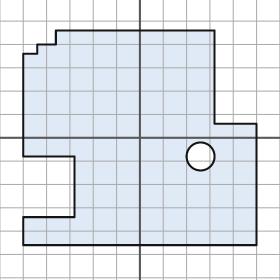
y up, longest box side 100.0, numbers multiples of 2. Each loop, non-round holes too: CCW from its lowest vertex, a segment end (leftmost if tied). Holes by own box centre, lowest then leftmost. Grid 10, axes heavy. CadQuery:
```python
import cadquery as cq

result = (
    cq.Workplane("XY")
    .moveTo(-50.0, -46.0)
    .lineTo(50.0, -46.0)
    .lineTo(50.0, 6.0)
    .lineTo(32.0, 6.0)
    .lineTo(32.0, 46.0)
    .lineTo(-36.0, 46.0)
    .lineTo(-36.0, 40.0)
    .lineTo(-44.0, 40.0)
    .lineTo(-44.0, 36.0)
    .lineTo(-50.0, 36.0)
    .lineTo(-50.0, -8.0)
    .lineTo(-28.0, -8.0)
    .lineTo(-28.0, -34.0)
    .lineTo(-50.0, -34.0)
    .close()
    .moveTo(26.0, -8.0)
    .circle(6.0)
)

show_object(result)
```